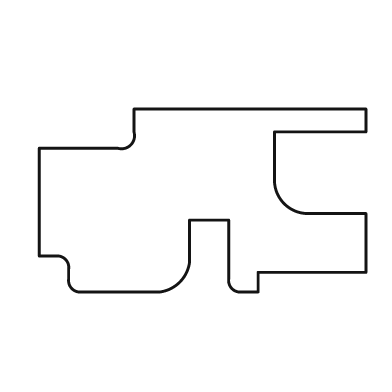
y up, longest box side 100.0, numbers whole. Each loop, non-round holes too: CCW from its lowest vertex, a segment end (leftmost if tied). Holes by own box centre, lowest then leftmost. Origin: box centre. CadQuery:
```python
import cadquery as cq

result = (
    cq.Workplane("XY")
    .moveTo(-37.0, -28.0)
    .lineTo(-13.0, -28.0)
    .threePointArc((-7.0, -25.0), (-4.0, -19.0))
    .lineTo(-4.0, -6.0)
    .lineTo(8.0, -6.0)
    .lineTo(8.0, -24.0)
    .threePointArc((9.0, -27.0), (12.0, -28.0))
    .lineTo(17.0, -28.0)
    .lineTo(17.0, -22.0)
    .lineTo(50.0, -22.0)
    .lineTo(50.0, -4.0)
    .lineTo(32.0, -4.0)
    .threePointArc((25.0, -1.0), (22.0, 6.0))
    .lineTo(22.0, 21.0)
    .lineTo(50.0, 21.0)
    .lineTo(50.0, 28.0)
    .lineTo(-21.0, 28.0)
    .lineTo(-21.0, 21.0)
    .threePointArc((-22.0, 17.0), (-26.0, 16.0))
    .lineTo(-50.0, 16.0)
    .lineTo(-50.0, -17.0)
    .lineTo(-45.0, -17.0)
    .threePointArc((-42.0, -18.0), (-41.0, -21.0))
    .lineTo(-41.0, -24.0)
    .threePointArc((-40.0, -27.0), (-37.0, -28.0))
    .close()
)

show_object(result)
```